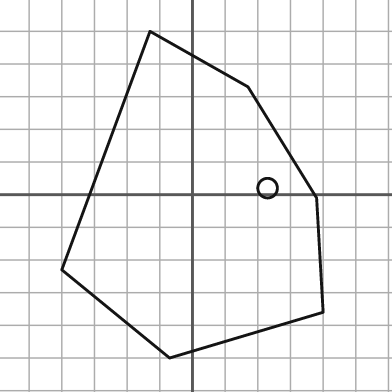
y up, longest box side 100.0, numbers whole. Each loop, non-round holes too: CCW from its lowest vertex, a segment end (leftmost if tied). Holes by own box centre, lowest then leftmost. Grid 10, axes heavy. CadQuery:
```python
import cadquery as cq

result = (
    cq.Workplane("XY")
    .moveTo(-7.0, -50.0)
    .lineTo(40.0, -36.0)
    .lineTo(38.0, -1.0)
    .lineTo(17.0, 33.0)
    .lineTo(-13.0, 50.0)
    .lineTo(-40.0, -23.0)
    .close()
    .moveTo(23.0, 2.0)
    .circle(3.0)
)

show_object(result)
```